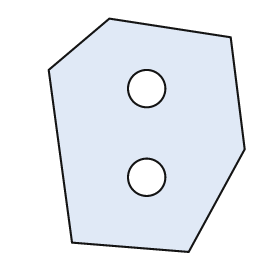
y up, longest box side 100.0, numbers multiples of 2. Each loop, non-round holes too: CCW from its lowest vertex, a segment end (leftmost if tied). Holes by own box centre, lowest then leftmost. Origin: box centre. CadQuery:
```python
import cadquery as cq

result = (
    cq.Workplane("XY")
    .moveTo(18.0, -50.0)
    .lineTo(42.0, -6.0)
    .lineTo(36.0, 42.0)
    .lineTo(-16.0, 50.0)
    .lineTo(-42.0, 28.0)
    .lineTo(-32.0, -46.0)
    .close()
    .moveTo(0.0, -18.0)
    .circle(8.0)
    .moveTo(0.0, 20.0)
    .circle(8.0)
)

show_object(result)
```